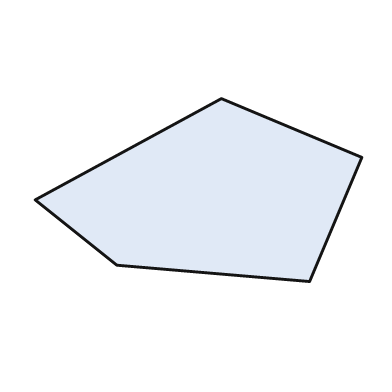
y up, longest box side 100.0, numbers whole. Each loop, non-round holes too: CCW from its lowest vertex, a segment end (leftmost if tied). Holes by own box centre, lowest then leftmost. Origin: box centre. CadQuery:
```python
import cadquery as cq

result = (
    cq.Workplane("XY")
    .moveTo(34.0, -28.0)
    .lineTo(50.0, 10.0)
    .lineTo(7.0, 28.0)
    .lineTo(-50.0, -3.0)
    .lineTo(-25.0, -23.0)
    .close()
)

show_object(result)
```